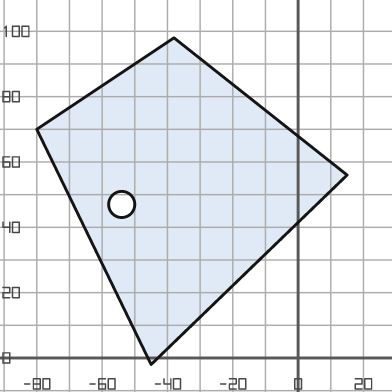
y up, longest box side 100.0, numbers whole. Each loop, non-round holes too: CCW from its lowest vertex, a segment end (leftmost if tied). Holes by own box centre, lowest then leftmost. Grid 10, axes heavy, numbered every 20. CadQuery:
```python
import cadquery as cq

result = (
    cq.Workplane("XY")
    .moveTo(-45.0, -2.0)
    .lineTo(15.0, 56.0)
    .lineTo(-38.0, 98.0)
    .lineTo(-80.0, 70.0)
    .close()
    .moveTo(-54.0, 47.0)
    .circle(4.0)
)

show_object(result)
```